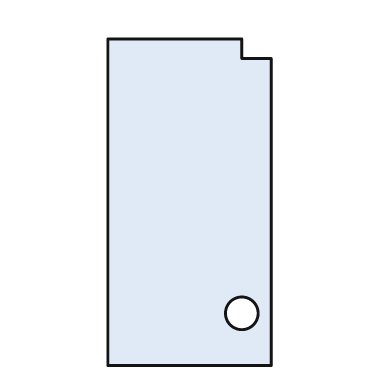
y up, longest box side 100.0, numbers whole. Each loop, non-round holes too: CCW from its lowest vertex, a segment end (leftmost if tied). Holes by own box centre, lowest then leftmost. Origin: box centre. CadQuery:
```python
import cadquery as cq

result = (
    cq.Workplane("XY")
    .moveTo(-25.0, -50.0)
    .lineTo(25.0, -50.0)
    .lineTo(25.0, 44.0)
    .lineTo(16.0, 44.0)
    .lineTo(16.0, 50.0)
    .lineTo(-25.0, 50.0)
    .close()
    .moveTo(16.0, -34.0)
    .circle(5.0)
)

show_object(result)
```